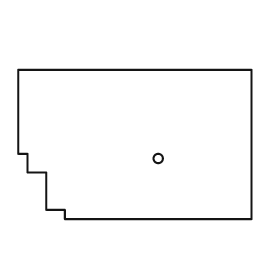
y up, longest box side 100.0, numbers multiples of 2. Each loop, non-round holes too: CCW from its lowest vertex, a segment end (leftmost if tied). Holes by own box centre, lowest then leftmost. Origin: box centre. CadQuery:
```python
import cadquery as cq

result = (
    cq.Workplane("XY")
    .moveTo(-30.0, -32.0)
    .lineTo(50.0, -32.0)
    .lineTo(50.0, 32.0)
    .lineTo(-50.0, 32.0)
    .lineTo(-50.0, -4.0)
    .lineTo(-46.0, -4.0)
    .lineTo(-46.0, -12.0)
    .lineTo(-38.0, -12.0)
    .lineTo(-38.0, -28.0)
    .lineTo(-30.0, -28.0)
    .close()
    .moveTo(10.0, -6.0)
    .circle(2.0)
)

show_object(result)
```